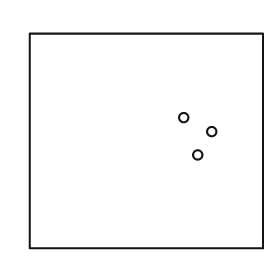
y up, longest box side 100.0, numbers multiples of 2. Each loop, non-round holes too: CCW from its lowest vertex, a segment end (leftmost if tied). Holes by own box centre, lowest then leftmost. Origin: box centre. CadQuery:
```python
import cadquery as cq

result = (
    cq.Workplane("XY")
    .moveTo(-50.0, -46.0)
    .lineTo(50.0, -46.0)
    .lineTo(50.0, 46.0)
    .lineTo(-50.0, 46.0)
    .close()
    .moveTo(22.0, -6.0)
    .circle(2.0)
    .moveTo(28.0, 4.0)
    .circle(2.0)
    .moveTo(16.0, 10.0)
    .circle(2.0)
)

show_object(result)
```